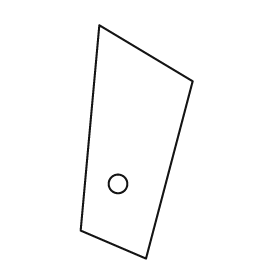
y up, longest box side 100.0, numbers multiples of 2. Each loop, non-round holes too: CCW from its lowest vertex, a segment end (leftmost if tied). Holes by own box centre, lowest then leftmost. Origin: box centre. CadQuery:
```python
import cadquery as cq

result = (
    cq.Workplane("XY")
    .moveTo(4.0, -50.0)
    .lineTo(24.0, 26.0)
    .lineTo(-16.0, 50.0)
    .lineTo(-24.0, -38.0)
    .close()
    .moveTo(-8.0, -18.0)
    .circle(4.0)
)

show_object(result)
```